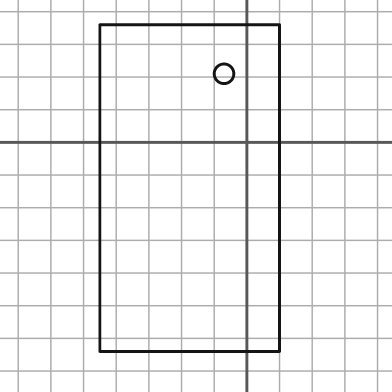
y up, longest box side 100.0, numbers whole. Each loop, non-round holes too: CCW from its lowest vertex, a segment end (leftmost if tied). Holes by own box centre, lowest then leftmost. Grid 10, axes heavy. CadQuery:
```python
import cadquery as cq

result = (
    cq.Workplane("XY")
    .moveTo(-45.0, -64.0)
    .lineTo(10.0, -64.0)
    .lineTo(10.0, 36.0)
    .lineTo(-45.0, 36.0)
    .close()
    .moveTo(-7.0, 21.0)
    .circle(3.0)
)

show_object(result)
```